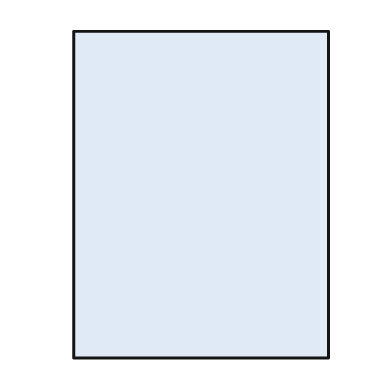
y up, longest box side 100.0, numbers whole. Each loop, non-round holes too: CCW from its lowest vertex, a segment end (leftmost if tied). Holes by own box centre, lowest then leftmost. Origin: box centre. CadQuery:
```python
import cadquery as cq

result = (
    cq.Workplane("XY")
    .moveTo(-39.0, -50.0)
    .lineTo(39.0, -50.0)
    .lineTo(39.0, 50.0)
    .lineTo(-39.0, 50.0)
    .close()
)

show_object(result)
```